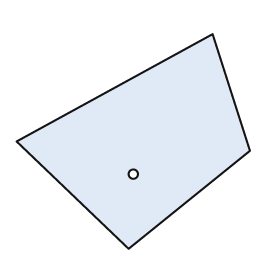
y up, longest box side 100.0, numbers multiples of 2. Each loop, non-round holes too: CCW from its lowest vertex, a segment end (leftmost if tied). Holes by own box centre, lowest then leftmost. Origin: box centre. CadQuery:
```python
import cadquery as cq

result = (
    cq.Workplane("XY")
    .moveTo(-2.0, -46.0)
    .lineTo(50.0, -4.0)
    .lineTo(34.0, 46.0)
    .lineTo(-50.0, 0.0)
    .close()
    .moveTo(0.0, -14.0)
    .circle(2.0)
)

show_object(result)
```